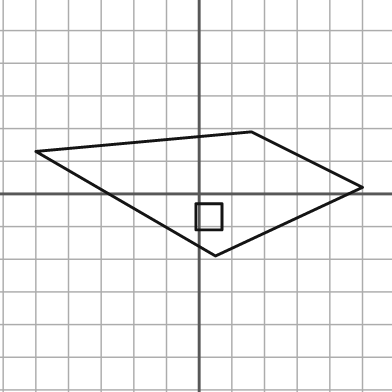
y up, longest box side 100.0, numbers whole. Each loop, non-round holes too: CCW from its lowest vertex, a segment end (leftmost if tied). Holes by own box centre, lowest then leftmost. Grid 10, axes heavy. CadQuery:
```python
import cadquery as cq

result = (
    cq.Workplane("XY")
    .moveTo(5.0, -19.0)
    .lineTo(50.0, 2.0)
    .lineTo(16.0, 19.0)
    .lineTo(-50.0, 13.0)
    .close()
    .moveTo(-1.0, -11.0)
    .lineTo(7.0, -11.0)
    .lineTo(7.0, -3.0)
    .lineTo(-1.0, -3.0)
    .close()
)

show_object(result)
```